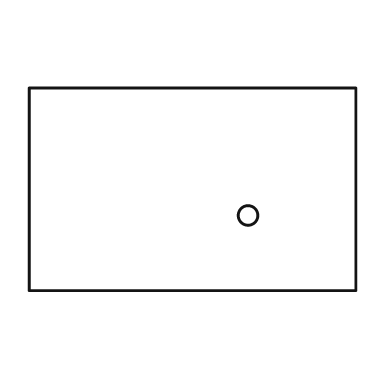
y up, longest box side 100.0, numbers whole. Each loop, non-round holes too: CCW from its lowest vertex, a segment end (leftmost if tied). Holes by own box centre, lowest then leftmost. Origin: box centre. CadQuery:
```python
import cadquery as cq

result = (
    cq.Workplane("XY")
    .moveTo(-50.0, -31.0)
    .lineTo(50.0, -31.0)
    .lineTo(50.0, 31.0)
    .lineTo(-50.0, 31.0)
    .close()
    .moveTo(17.0, -8.0)
    .circle(3.0)
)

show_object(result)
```